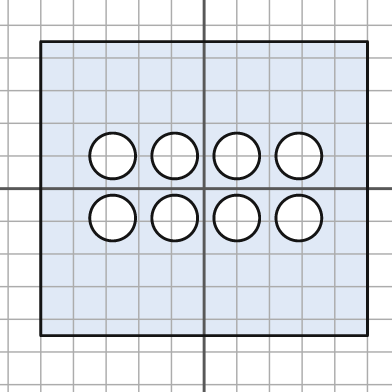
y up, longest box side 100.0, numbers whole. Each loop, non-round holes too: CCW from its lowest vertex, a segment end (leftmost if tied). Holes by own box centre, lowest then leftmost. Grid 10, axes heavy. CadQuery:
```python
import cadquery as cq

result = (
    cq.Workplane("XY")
    .moveTo(-50.0, -45.0)
    .lineTo(50.0, -45.0)
    .lineTo(50.0, 45.0)
    .lineTo(-50.0, 45.0)
    .close()
    .moveTo(-28.0, -9.0)
    .circle(7.0)
    .moveTo(-9.0, -9.0)
    .circle(7.0)
    .moveTo(10.0, -9.0)
    .circle(7.0)
    .moveTo(29.0, -9.0)
    .circle(7.0)
    .moveTo(-28.0, 10.0)
    .circle(7.0)
    .moveTo(-9.0, 10.0)
    .circle(7.0)
    .moveTo(10.0, 10.0)
    .circle(7.0)
    .moveTo(29.0, 10.0)
    .circle(7.0)
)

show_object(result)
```